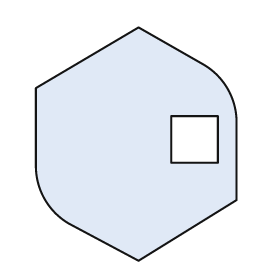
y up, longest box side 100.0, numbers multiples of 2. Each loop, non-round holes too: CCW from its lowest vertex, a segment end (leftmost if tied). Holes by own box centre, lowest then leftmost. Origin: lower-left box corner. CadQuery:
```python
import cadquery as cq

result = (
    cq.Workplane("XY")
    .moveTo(44.0, 0.0)
    .lineTo(86.0, 26.0)
    .lineTo(86.0, 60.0)
    .threePointArc((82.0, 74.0), (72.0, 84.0))
    .lineTo(44.0, 100.0)
    .lineTo(0.0, 74.0)
    .lineTo(0.0, 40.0)
    .threePointArc((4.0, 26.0), (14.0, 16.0))
    .close()
    .moveTo(58.0, 42.0)
    .lineTo(78.0, 42.0)
    .lineTo(78.0, 62.0)
    .lineTo(58.0, 62.0)
    .close()
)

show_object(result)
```